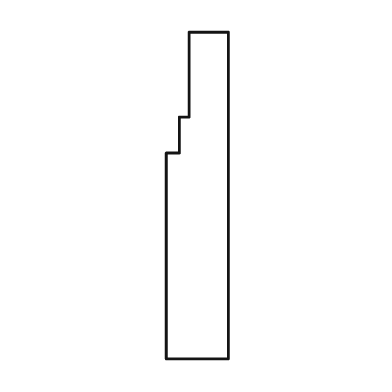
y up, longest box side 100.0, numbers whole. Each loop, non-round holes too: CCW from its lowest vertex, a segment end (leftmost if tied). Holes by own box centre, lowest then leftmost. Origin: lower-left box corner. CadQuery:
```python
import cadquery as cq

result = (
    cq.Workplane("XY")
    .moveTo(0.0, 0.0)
    .lineTo(19.0, 0.0)
    .lineTo(19.0, 100.0)
    .lineTo(7.0, 100.0)
    .lineTo(7.0, 74.0)
    .lineTo(4.0, 74.0)
    .lineTo(4.0, 63.0)
    .lineTo(0.0, 63.0)
    .close()
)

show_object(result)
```